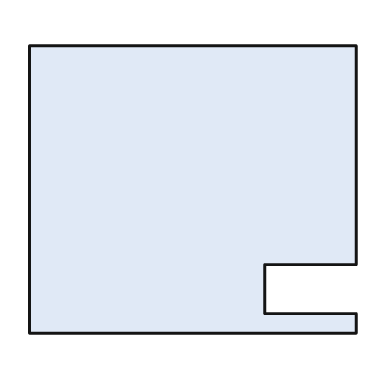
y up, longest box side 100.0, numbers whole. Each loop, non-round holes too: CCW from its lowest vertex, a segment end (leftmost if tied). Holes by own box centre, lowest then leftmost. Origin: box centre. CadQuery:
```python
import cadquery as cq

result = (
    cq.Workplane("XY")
    .moveTo(-50.0, -44.0)
    .lineTo(50.0, -44.0)
    .lineTo(50.0, -38.0)
    .lineTo(22.0, -38.0)
    .lineTo(22.0, -23.0)
    .lineTo(50.0, -23.0)
    .lineTo(50.0, 44.0)
    .lineTo(-50.0, 44.0)
    .close()
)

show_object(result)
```